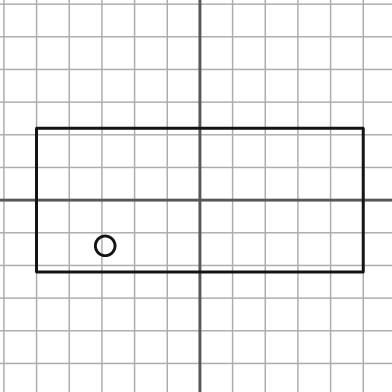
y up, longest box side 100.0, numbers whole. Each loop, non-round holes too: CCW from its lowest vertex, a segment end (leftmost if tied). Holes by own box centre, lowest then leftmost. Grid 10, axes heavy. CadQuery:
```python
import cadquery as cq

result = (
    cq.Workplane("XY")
    .moveTo(-50.0, -22.0)
    .lineTo(50.0, -22.0)
    .lineTo(50.0, 22.0)
    .lineTo(-50.0, 22.0)
    .close()
    .moveTo(-29.0, -14.0)
    .circle(3.0)
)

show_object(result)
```